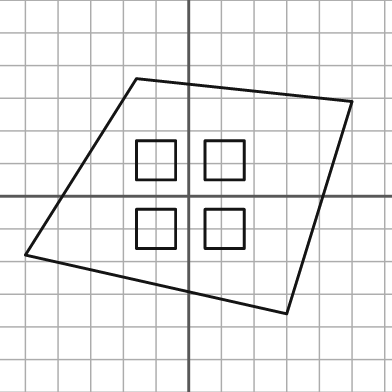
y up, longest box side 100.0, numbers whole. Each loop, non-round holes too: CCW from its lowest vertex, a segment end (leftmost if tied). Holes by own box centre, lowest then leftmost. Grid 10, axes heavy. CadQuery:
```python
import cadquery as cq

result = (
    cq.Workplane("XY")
    .moveTo(30.0, -36.0)
    .lineTo(50.0, 29.0)
    .lineTo(-16.0, 36.0)
    .lineTo(-50.0, -18.0)
    .close()
    .moveTo(-16.0, -16.0)
    .lineTo(-4.0, -16.0)
    .lineTo(-4.0, -4.0)
    .lineTo(-16.0, -4.0)
    .close()
    .moveTo(5.0, -16.0)
    .lineTo(17.0, -16.0)
    .lineTo(17.0, -4.0)
    .lineTo(5.0, -4.0)
    .close()
    .moveTo(-16.0, 5.0)
    .lineTo(-4.0, 5.0)
    .lineTo(-4.0, 17.0)
    .lineTo(-16.0, 17.0)
    .close()
    .moveTo(5.0, 5.0)
    .lineTo(17.0, 5.0)
    .lineTo(17.0, 17.0)
    .lineTo(5.0, 17.0)
    .close()
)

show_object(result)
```